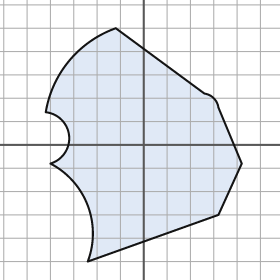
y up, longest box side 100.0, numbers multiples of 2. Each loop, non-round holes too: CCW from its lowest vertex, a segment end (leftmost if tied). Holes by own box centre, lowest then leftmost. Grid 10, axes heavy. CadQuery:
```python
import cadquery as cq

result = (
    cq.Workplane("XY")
    .moveTo(-24.0, -50.0)
    .lineTo(32.0, -30.0)
    .lineTo(42.0, -8.0)
    .lineTo(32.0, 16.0)
    .threePointArc((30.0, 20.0), (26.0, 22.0))
    .lineTo(-12.0, 50.0)
    .threePointArc((-32.0, 36.0), (-42.0, 14.0))
    .threePointArc((-32.0, 4.0), (-40.0, -8.0))
    .threePointArc((-24.0, -26.0), (-24.0, -50.0))
    .close()
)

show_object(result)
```